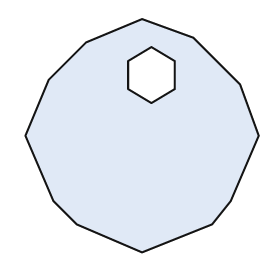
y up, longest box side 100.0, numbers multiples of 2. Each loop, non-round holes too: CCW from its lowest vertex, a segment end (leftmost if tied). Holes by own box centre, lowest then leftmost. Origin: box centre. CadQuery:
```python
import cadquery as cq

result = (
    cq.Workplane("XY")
    .moveTo(0.0, -50.0)
    .lineTo(30.0, -38.0)
    .lineTo(38.0, -28.0)
    .lineTo(50.0, 0.0)
    .lineTo(42.0, 22.0)
    .lineTo(22.0, 42.0)
    .lineTo(0.0, 50.0)
    .lineTo(-24.0, 40.0)
    .lineTo(-40.0, 24.0)
    .lineTo(-50.0, 0.0)
    .lineTo(-38.0, -28.0)
    .lineTo(-28.0, -38.0)
    .close()
    .moveTo(4.0, 14.0)
    .lineTo(14.0, 20.0)
    .lineTo(14.0, 32.0)
    .lineTo(4.0, 38.0)
    .lineTo(-6.0, 32.0)
    .lineTo(-6.0, 20.0)
    .close()
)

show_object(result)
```